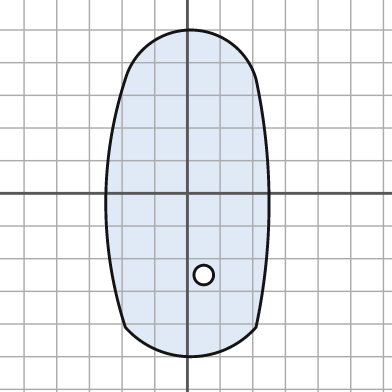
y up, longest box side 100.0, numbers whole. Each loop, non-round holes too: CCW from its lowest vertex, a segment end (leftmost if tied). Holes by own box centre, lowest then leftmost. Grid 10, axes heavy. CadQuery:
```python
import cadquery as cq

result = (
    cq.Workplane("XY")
    .moveTo(-19.0, -41.0)
    .threePointArc((1.0, -50.0), (21.0, -41.0))
    .threePointArc((25.0, -3.0), (21.0, 35.0))
    .threePointArc((1.0, 50.0), (-19.0, 35.0))
    .threePointArc((-25.0, -3.0), (-19.0, -41.0))
    .close()
    .moveTo(5.0, -25.0)
    .circle(3.0)
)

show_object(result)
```